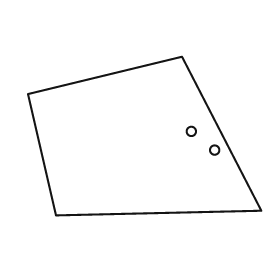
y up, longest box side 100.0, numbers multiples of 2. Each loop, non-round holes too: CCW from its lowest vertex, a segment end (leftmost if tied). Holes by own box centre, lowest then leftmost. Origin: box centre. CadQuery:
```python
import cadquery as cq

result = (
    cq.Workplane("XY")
    .moveTo(-38.0, -34.0)
    .lineTo(50.0, -32.0)
    .lineTo(16.0, 34.0)
    .lineTo(-50.0, 18.0)
    .close()
    .moveTo(30.0, -6.0)
    .circle(2.0)
    .moveTo(20.0, 2.0)
    .circle(2.0)
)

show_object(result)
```